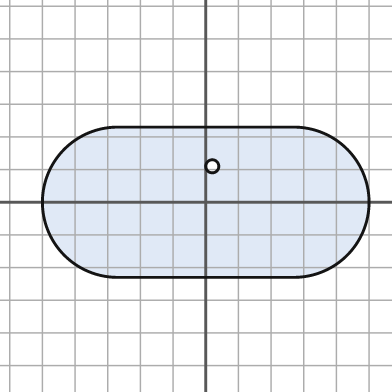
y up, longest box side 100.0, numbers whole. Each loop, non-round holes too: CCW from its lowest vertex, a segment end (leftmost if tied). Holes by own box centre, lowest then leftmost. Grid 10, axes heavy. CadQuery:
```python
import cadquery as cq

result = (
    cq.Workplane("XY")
    .moveTo(-27.0, -23.0)
    .lineTo(27.0, -23.0)
    .threePointArc((50.0, 0.0), (27.0, 23.0))
    .lineTo(-27.0, 23.0)
    .threePointArc((-50.0, 0.0), (-27.0, -23.0))
    .close()
    .moveTo(2.0, 11.0)
    .circle(2.0)
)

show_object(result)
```